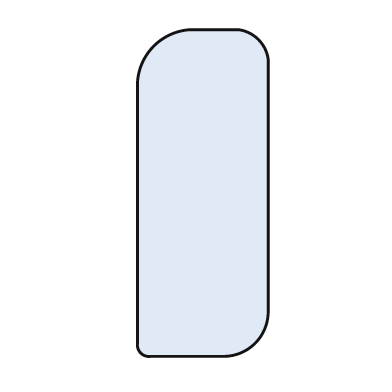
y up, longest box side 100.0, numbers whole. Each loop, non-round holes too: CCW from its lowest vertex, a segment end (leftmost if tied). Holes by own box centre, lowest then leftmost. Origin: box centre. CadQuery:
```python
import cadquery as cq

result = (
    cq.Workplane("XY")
    .moveTo(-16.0, -50.0)
    .lineTo(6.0, -50.0)
    .threePointArc((16.0, -46.0), (20.0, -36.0))
    .lineTo(20.0, 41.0)
    .threePointArc((17.0, 47.0), (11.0, 50.0))
    .lineTo(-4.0, 50.0)
    .threePointArc((-15.0, 45.0), (-20.0, 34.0))
    .lineTo(-20.0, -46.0)
    .threePointArc((-19.0, -49.0), (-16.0, -50.0))
    .close()
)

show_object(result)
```